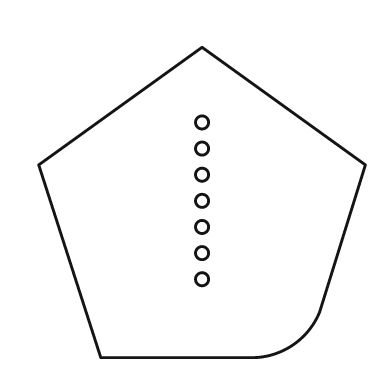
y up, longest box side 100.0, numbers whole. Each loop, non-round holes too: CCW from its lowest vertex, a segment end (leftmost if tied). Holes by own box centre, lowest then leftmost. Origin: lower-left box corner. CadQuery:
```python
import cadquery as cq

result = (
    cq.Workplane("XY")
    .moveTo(19.0, 0.0)
    .lineTo(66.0, 0.0)
    .threePointArc((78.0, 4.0), (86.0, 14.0))
    .lineTo(100.0, 59.0)
    .lineTo(50.0, 95.0)
    .lineTo(0.0, 59.0)
    .close()
    .moveTo(50.0, 24.0)
    .circle(2.0)
    .moveTo(50.0, 32.0)
    .circle(2.0)
    .moveTo(50.0, 40.0)
    .circle(2.0)
    .moveTo(50.0, 48.0)
    .circle(2.0)
    .moveTo(50.0, 56.0)
    .circle(2.0)
    .moveTo(50.0, 64.0)
    .circle(2.0)
    .moveTo(50.0, 72.0)
    .circle(2.0)
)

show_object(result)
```